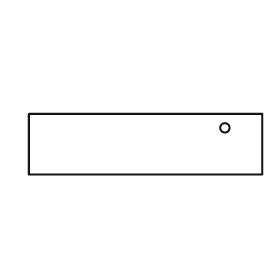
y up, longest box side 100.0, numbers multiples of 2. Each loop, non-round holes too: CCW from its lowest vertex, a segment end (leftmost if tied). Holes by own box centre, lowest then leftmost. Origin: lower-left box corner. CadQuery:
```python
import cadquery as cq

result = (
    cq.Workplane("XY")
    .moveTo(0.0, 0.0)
    .lineTo(100.0, 0.0)
    .lineTo(100.0, 26.0)
    .lineTo(0.0, 26.0)
    .close()
    .moveTo(84.0, 20.0)
    .circle(2.0)
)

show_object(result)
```